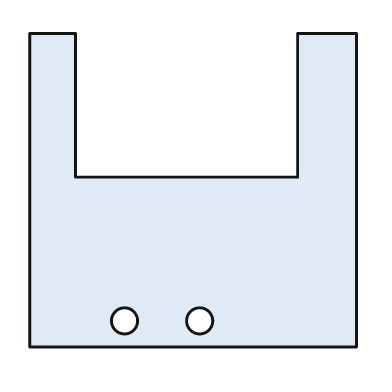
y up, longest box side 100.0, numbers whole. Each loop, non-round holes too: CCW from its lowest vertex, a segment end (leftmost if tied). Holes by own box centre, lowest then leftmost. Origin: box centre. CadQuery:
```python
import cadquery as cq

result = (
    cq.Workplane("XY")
    .moveTo(-50.0, -48.0)
    .lineTo(50.0, -48.0)
    .lineTo(50.0, 48.0)
    .lineTo(32.0, 48.0)
    .lineTo(32.0, 4.0)
    .lineTo(-36.0, 4.0)
    .lineTo(-36.0, 48.0)
    .lineTo(-50.0, 48.0)
    .close()
    .moveTo(-21.0, -40.0)
    .circle(4.0)
    .moveTo(2.0, -40.0)
    .circle(4.0)
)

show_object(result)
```